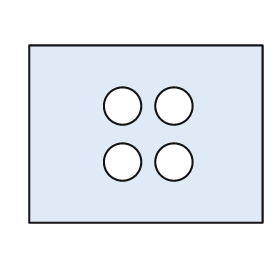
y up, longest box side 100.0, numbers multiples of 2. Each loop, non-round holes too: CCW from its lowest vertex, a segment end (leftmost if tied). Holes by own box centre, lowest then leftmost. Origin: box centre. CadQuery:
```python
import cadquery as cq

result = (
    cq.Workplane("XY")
    .moveTo(-50.0, -38.0)
    .lineTo(50.0, -38.0)
    .lineTo(50.0, 38.0)
    .lineTo(-50.0, 38.0)
    .close()
    .moveTo(-10.0, -12.0)
    .circle(8.0)
    .moveTo(12.0, -12.0)
    .circle(8.0)
    .moveTo(-10.0, 12.0)
    .circle(8.0)
    .moveTo(12.0, 12.0)
    .circle(8.0)
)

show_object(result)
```